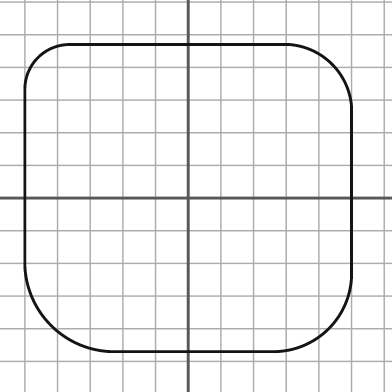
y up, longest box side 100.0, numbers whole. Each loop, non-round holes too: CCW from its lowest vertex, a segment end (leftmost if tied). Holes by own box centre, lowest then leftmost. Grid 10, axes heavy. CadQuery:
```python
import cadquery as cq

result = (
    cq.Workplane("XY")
    .moveTo(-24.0, -47.0)
    .lineTo(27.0, -47.0)
    .threePointArc((43.0, -40.0), (50.0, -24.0))
    .lineTo(50.0, 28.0)
    .threePointArc((44.0, 41.0), (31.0, 47.0))
    .lineTo(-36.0, 47.0)
    .threePointArc((-46.0, 43.0), (-50.0, 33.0))
    .lineTo(-50.0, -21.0)
    .threePointArc((-42.0, -39.0), (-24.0, -47.0))
    .close()
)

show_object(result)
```